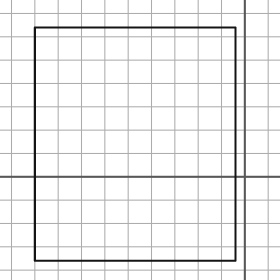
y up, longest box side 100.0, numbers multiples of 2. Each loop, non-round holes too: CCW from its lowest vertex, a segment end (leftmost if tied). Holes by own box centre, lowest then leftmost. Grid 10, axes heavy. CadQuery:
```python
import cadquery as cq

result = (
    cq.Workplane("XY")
    .moveTo(-90.0, -36.0)
    .lineTo(-4.0, -36.0)
    .lineTo(-4.0, 64.0)
    .lineTo(-90.0, 64.0)
    .close()
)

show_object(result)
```